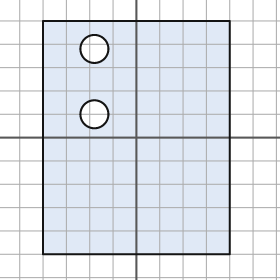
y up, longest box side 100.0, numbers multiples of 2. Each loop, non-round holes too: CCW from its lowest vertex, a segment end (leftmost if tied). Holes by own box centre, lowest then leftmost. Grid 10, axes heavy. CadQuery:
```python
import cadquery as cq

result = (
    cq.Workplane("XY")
    .moveTo(-40.0, -50.0)
    .lineTo(40.0, -50.0)
    .lineTo(40.0, 50.0)
    .lineTo(-40.0, 50.0)
    .close()
    .moveTo(-18.0, 10.0)
    .circle(6.0)
    .moveTo(-18.0, 38.0)
    .circle(6.0)
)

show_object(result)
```